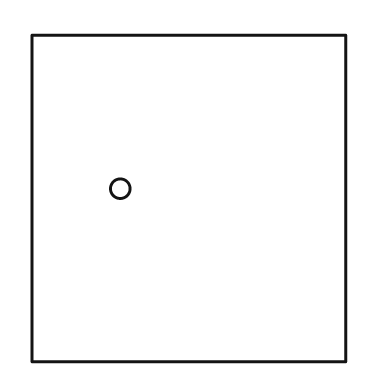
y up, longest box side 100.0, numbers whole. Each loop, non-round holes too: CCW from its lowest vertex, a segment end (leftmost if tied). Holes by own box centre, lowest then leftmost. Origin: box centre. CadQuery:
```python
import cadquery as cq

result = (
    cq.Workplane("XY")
    .moveTo(-48.0, -50.0)
    .lineTo(48.0, -50.0)
    .lineTo(48.0, 50.0)
    .lineTo(-48.0, 50.0)
    .close()
    .moveTo(-21.0, 3.0)
    .circle(3.0)
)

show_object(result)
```